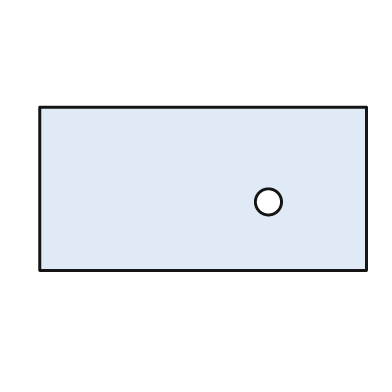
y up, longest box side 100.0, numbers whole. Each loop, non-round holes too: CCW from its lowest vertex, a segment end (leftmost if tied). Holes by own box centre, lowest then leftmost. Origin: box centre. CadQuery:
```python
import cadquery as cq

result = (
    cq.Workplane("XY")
    .moveTo(-50.0, -25.0)
    .lineTo(50.0, -25.0)
    .lineTo(50.0, 25.0)
    .lineTo(-50.0, 25.0)
    .close()
    .moveTo(20.0, -4.0)
    .circle(4.0)
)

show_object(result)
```